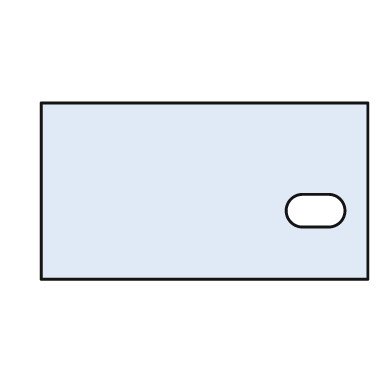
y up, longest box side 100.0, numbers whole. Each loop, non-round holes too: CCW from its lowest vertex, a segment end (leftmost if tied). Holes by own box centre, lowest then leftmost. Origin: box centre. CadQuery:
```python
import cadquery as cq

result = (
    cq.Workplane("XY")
    .moveTo(-50.0, -27.0)
    .lineTo(50.0, -27.0)
    .lineTo(50.0, 27.0)
    .lineTo(-50.0, 27.0)
    .close()
    .moveTo(30.0, -11.0)
    .lineTo(38.0, -11.0)
    .threePointArc((43.0, -6.0), (38.0, -1.0))
    .lineTo(30.0, -1.0)
    .threePointArc((25.0, -6.0), (30.0, -11.0))
    .close()
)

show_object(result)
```